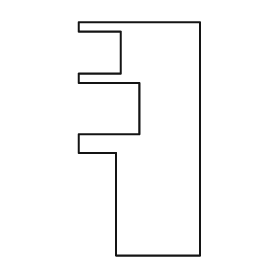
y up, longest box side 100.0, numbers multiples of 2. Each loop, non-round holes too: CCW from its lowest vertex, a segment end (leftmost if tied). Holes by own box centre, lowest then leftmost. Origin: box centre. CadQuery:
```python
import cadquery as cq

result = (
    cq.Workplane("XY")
    .moveTo(-10.0, -50.0)
    .lineTo(26.0, -50.0)
    .lineTo(26.0, 50.0)
    .lineTo(-26.0, 50.0)
    .lineTo(-26.0, 46.0)
    .lineTo(-8.0, 46.0)
    .lineTo(-8.0, 28.0)
    .lineTo(-26.0, 28.0)
    .lineTo(-26.0, 24.0)
    .lineTo(0.0, 24.0)
    .lineTo(0.0, 2.0)
    .lineTo(-26.0, 2.0)
    .lineTo(-26.0, -6.0)
    .lineTo(-10.0, -6.0)
    .close()
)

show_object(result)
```